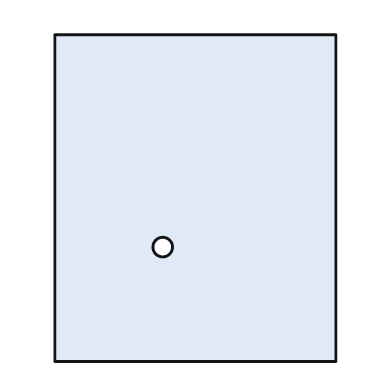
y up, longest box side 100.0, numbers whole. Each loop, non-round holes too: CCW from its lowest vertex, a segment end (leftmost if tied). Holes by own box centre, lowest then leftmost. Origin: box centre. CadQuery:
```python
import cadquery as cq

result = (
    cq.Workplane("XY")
    .moveTo(-43.0, -50.0)
    .lineTo(43.0, -50.0)
    .lineTo(43.0, 50.0)
    .lineTo(-43.0, 50.0)
    .close()
    .moveTo(-10.0, -15.0)
    .circle(3.0)
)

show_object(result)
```